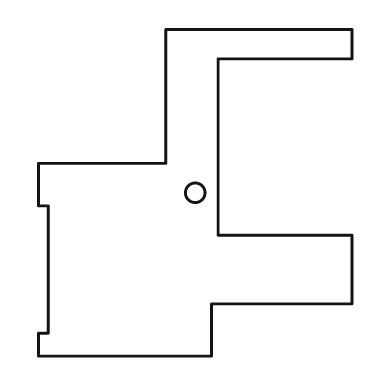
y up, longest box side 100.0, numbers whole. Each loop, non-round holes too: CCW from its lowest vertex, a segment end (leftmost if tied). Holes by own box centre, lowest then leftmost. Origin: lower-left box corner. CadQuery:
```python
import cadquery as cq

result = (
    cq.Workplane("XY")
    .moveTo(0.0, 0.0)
    .lineTo(53.0, 0.0)
    .lineTo(53.0, 16.0)
    .lineTo(96.0, 16.0)
    .lineTo(96.0, 37.0)
    .lineTo(55.0, 37.0)
    .lineTo(55.0, 91.0)
    .lineTo(96.0, 91.0)
    .lineTo(96.0, 100.0)
    .lineTo(39.0, 100.0)
    .lineTo(39.0, 59.0)
    .lineTo(0.0, 59.0)
    .lineTo(0.0, 46.0)
    .lineTo(3.0, 46.0)
    .lineTo(3.0, 7.0)
    .lineTo(0.0, 7.0)
    .close()
    .moveTo(48.0, 50.0)
    .circle(3.0)
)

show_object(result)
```